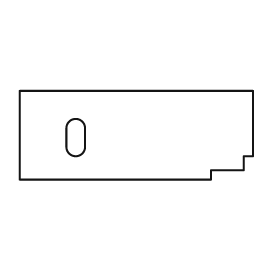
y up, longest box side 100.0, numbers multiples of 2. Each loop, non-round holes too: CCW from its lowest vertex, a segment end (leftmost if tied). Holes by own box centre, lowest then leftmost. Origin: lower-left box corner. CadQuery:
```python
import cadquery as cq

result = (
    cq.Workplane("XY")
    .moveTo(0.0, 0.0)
    .lineTo(82.0, 0.0)
    .lineTo(82.0, 4.0)
    .lineTo(96.0, 4.0)
    .lineTo(96.0, 10.0)
    .lineTo(100.0, 10.0)
    .lineTo(100.0, 38.0)
    .lineTo(0.0, 38.0)
    .close()
    .moveTo(20.0, 14.0)
    .threePointArc((24.0, 10.0), (28.0, 14.0))
    .lineTo(28.0, 22.0)
    .threePointArc((24.0, 26.0), (20.0, 22.0))
    .close()
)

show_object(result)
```